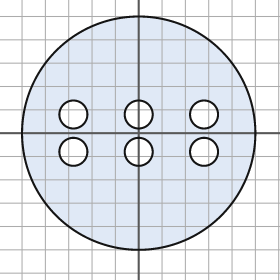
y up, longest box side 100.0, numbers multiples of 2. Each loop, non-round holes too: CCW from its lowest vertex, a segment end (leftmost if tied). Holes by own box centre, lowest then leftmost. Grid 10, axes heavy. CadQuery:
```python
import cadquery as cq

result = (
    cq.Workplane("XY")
    .moveTo(0.0, 0.0)
    .circle(50.0)
    .moveTo(-28.0, -8.0)
    .circle(6.0)
    .moveTo(0.0, -8.0)
    .circle(6.0)
    .moveTo(28.0, -8.0)
    .circle(6.0)
    .moveTo(-28.0, 8.0)
    .circle(6.0)
    .moveTo(0.0, 8.0)
    .circle(6.0)
    .moveTo(28.0, 8.0)
    .circle(6.0)
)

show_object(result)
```